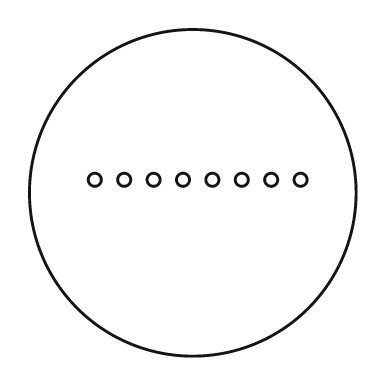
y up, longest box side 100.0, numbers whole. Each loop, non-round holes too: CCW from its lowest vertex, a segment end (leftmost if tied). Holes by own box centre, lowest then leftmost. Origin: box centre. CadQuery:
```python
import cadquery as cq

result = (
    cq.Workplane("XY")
    .moveTo(0.0, 0.0)
    .circle(50.0)
    .moveTo(-30.0, 4.0)
    .circle(2.0)
    .moveTo(-21.0, 4.0)
    .circle(2.0)
    .moveTo(-12.0, 4.0)
    .circle(2.0)
    .moveTo(-3.0, 4.0)
    .circle(2.0)
    .moveTo(6.0, 4.0)
    .circle(2.0)
    .moveTo(15.0, 4.0)
    .circle(2.0)
    .moveTo(24.0, 4.0)
    .circle(2.0)
    .moveTo(33.0, 4.0)
    .circle(2.0)
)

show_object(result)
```